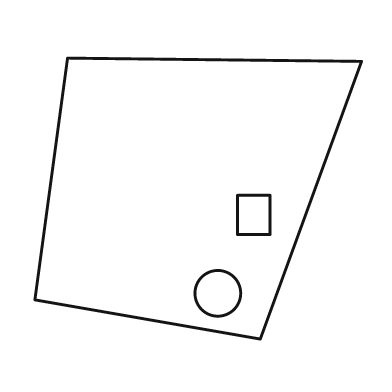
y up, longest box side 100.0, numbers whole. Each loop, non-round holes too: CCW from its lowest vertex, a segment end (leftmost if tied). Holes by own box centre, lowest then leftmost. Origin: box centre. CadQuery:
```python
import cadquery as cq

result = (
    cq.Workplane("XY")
    .moveTo(19.0, -43.0)
    .lineTo(50.0, 42.0)
    .lineTo(-40.0, 43.0)
    .lineTo(-50.0, -31.0)
    .close()
    .moveTo(6.0, -29.0)
    .circle(7.0)
    .moveTo(12.0, -11.0)
    .lineTo(22.0, -11.0)
    .lineTo(22.0, 1.0)
    .lineTo(12.0, 1.0)
    .close()
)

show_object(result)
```